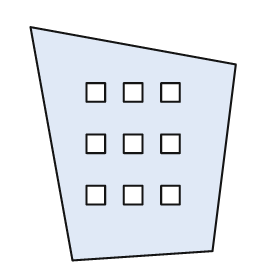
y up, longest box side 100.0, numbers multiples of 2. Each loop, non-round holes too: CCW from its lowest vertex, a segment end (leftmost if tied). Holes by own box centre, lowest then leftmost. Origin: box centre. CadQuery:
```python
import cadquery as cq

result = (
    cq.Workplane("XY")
    .moveTo(-26.0, -50.0)
    .lineTo(34.0, -46.0)
    .lineTo(44.0, 34.0)
    .lineTo(-44.0, 50.0)
    .close()
    .moveTo(-20.0, -26.0)
    .lineTo(-12.0, -26.0)
    .lineTo(-12.0, -18.0)
    .lineTo(-20.0, -18.0)
    .close()
    .moveTo(-4.0, -26.0)
    .lineTo(4.0, -26.0)
    .lineTo(4.0, -18.0)
    .lineTo(-4.0, -18.0)
    .close()
    .moveTo(12.0, -26.0)
    .lineTo(20.0, -26.0)
    .lineTo(20.0, -18.0)
    .lineTo(12.0, -18.0)
    .close()
    .moveTo(-20.0, -4.0)
    .lineTo(-12.0, -4.0)
    .lineTo(-12.0, 4.0)
    .lineTo(-20.0, 4.0)
    .close()
    .moveTo(-4.0, -4.0)
    .lineTo(4.0, -4.0)
    .lineTo(4.0, 4.0)
    .lineTo(-4.0, 4.0)
    .close()
    .moveTo(12.0, -4.0)
    .lineTo(20.0, -4.0)
    .lineTo(20.0, 4.0)
    .lineTo(12.0, 4.0)
    .close()
    .moveTo(-20.0, 18.0)
    .lineTo(-12.0, 18.0)
    .lineTo(-12.0, 26.0)
    .lineTo(-20.0, 26.0)
    .close()
    .moveTo(-4.0, 18.0)
    .lineTo(4.0, 18.0)
    .lineTo(4.0, 26.0)
    .lineTo(-4.0, 26.0)
    .close()
    .moveTo(12.0, 18.0)
    .lineTo(20.0, 18.0)
    .lineTo(20.0, 26.0)
    .lineTo(12.0, 26.0)
    .close()
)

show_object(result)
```